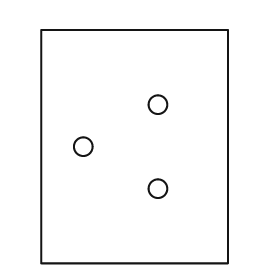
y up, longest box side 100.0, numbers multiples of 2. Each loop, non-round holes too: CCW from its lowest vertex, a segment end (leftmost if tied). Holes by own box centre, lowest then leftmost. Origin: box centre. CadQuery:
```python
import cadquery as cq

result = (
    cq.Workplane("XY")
    .moveTo(-40.0, -50.0)
    .lineTo(40.0, -50.0)
    .lineTo(40.0, 50.0)
    .lineTo(-40.0, 50.0)
    .close()
    .moveTo(10.0, -18.0)
    .circle(4.0)
    .moveTo(-22.0, 0.0)
    .circle(4.0)
    .moveTo(10.0, 18.0)
    .circle(4.0)
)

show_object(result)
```